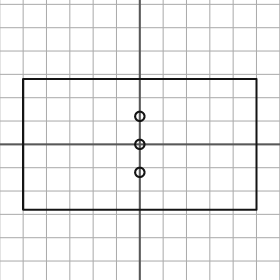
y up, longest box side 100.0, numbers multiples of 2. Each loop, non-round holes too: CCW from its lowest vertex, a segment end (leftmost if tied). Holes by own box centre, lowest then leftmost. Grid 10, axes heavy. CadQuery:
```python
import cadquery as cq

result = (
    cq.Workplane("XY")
    .moveTo(-50.0, -28.0)
    .lineTo(50.0, -28.0)
    .lineTo(50.0, 28.0)
    .lineTo(-50.0, 28.0)
    .close()
    .moveTo(0.0, -12.0)
    .circle(2.0)
    .moveTo(0.0, 0.0)
    .circle(2.0)
    .moveTo(0.0, 12.0)
    .circle(2.0)
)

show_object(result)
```